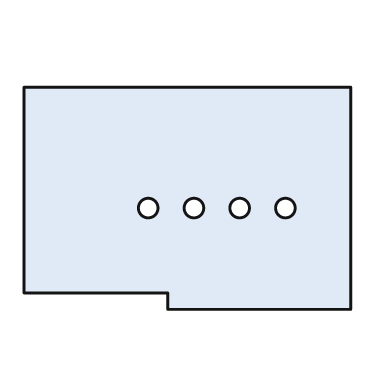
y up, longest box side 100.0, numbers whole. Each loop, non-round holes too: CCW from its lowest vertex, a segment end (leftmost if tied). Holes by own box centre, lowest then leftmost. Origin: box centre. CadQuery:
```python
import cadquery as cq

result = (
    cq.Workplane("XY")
    .moveTo(-6.0, -34.0)
    .lineTo(50.0, -34.0)
    .lineTo(50.0, 34.0)
    .lineTo(-50.0, 34.0)
    .lineTo(-50.0, -29.0)
    .lineTo(-6.0, -29.0)
    .close()
    .moveTo(-12.0, -3.0)
    .circle(3.0)
    .moveTo(2.0, -3.0)
    .circle(3.0)
    .moveTo(16.0, -3.0)
    .circle(3.0)
    .moveTo(30.0, -3.0)
    .circle(3.0)
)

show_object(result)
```